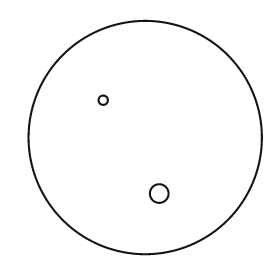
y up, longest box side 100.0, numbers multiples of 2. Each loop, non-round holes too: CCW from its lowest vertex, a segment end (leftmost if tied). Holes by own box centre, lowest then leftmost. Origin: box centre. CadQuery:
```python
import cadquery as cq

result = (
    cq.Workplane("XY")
    .moveTo(0.0, 0.0)
    .circle(50.0)
    .moveTo(6.0, -24.0)
    .circle(4.0)
    .moveTo(-18.0, 16.0)
    .circle(2.0)
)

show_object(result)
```